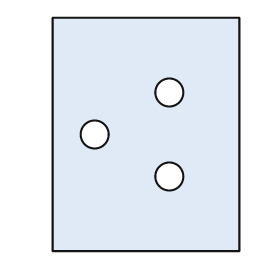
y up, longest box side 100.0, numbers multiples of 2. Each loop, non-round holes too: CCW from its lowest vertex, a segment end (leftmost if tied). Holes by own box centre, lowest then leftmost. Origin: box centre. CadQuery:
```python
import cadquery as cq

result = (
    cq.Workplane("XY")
    .moveTo(-40.0, -50.0)
    .lineTo(40.0, -50.0)
    .lineTo(40.0, 50.0)
    .lineTo(-40.0, 50.0)
    .close()
    .moveTo(10.0, -18.0)
    .circle(6.0)
    .moveTo(-22.0, 0.0)
    .circle(6.0)
    .moveTo(10.0, 18.0)
    .circle(6.0)
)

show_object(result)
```